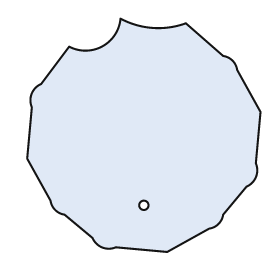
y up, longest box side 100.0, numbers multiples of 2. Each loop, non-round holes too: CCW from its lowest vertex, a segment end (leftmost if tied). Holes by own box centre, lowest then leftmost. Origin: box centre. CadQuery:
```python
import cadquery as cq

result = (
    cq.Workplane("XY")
    .moveTo(10.0, -50.0)
    .lineTo(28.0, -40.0)
    .threePointArc((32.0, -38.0), (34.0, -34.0))
    .lineTo(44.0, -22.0)
    .threePointArc((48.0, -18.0), (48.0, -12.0))
    .lineTo(50.0, 10.0)
    .lineTo(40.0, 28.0)
    .threePointArc((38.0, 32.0), (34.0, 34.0))
    .lineTo(18.0, 48.0)
    .threePointArc((4.0, 46.0), (-10.0, 50.0))
    .threePointArc((-18.0, 38.0), (-32.0, 38.0))
    .lineTo(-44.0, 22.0)
    .threePointArc((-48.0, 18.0), (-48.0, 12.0))
    .lineTo(-50.0, -10.0)
    .lineTo(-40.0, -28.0)
    .threePointArc((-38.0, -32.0), (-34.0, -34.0))
    .lineTo(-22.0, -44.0)
    .threePointArc((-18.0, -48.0), (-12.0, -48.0))
    .close()
    .moveTo(0.0, -30.0)
    .circle(2.0)
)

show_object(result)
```